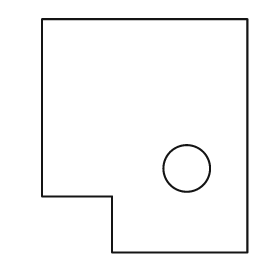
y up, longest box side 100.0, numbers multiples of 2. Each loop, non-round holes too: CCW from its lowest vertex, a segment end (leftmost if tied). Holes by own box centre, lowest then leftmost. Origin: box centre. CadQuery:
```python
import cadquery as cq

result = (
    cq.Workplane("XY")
    .moveTo(-14.0, -50.0)
    .lineTo(44.0, -50.0)
    .lineTo(44.0, 50.0)
    .lineTo(-44.0, 50.0)
    .lineTo(-44.0, -26.0)
    .lineTo(-14.0, -26.0)
    .close()
    .moveTo(18.0, -14.0)
    .circle(10.0)
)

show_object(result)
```